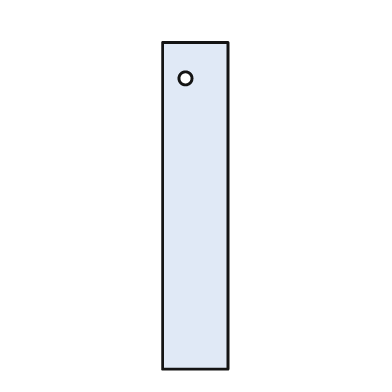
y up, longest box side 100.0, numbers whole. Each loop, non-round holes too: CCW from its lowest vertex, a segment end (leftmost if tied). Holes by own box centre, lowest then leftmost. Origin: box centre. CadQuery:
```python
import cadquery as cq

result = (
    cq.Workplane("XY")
    .moveTo(-10.0, -50.0)
    .lineTo(10.0, -50.0)
    .lineTo(10.0, 50.0)
    .lineTo(-10.0, 50.0)
    .close()
    .moveTo(-3.0, 39.0)
    .circle(2.0)
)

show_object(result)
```